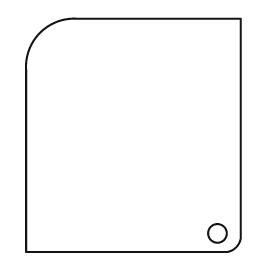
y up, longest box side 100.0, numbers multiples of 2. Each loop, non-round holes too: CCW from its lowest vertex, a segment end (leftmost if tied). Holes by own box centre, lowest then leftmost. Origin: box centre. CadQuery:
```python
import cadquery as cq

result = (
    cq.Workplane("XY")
    .moveTo(-46.0, -50.0)
    .lineTo(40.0, -50.0)
    .threePointArc((44.0, -48.0), (46.0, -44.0))
    .lineTo(46.0, 50.0)
    .lineTo(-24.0, 50.0)
    .threePointArc((-40.0, 44.0), (-46.0, 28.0))
    .close()
    .moveTo(36.0, -42.0)
    .circle(4.0)
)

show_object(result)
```